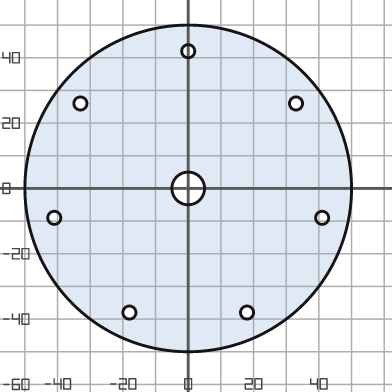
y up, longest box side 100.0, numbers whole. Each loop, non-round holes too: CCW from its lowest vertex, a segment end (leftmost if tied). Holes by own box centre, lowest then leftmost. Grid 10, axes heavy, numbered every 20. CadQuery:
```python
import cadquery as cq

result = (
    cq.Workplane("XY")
    .moveTo(0.0, 0.0)
    .circle(50.0)
    .moveTo(-18.0, -38.0)
    .circle(2.0)
    .moveTo(18.0, -38.0)
    .circle(2.0)
    .moveTo(-41.0, -9.0)
    .circle(2.0)
    .moveTo(41.0, -9.0)
    .circle(2.0)
    .moveTo(0.0, 0.0)
    .circle(5.0)
    .moveTo(-33.0, 26.0)
    .circle(2.0)
    .moveTo(33.0, 26.0)
    .circle(2.0)
    .moveTo(0.0, 42.0)
    .circle(2.0)
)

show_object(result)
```